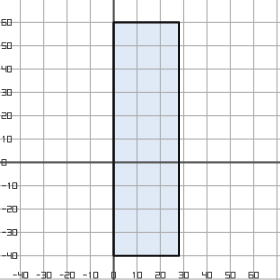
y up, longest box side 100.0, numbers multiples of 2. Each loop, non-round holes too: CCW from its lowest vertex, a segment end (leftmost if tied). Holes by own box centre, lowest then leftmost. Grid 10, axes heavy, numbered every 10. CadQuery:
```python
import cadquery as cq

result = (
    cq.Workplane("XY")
    .moveTo(0.0, -40.0)
    .lineTo(28.0, -40.0)
    .lineTo(28.0, 60.0)
    .lineTo(0.0, 60.0)
    .close()
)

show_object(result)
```